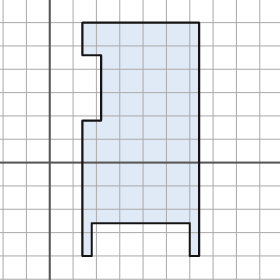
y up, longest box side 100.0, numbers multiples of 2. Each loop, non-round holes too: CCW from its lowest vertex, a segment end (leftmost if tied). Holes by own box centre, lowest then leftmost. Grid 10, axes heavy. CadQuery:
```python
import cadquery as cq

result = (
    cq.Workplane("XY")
    .moveTo(14.0, -40.0)
    .lineTo(18.0, -40.0)
    .lineTo(18.0, -26.0)
    .lineTo(60.0, -26.0)
    .lineTo(60.0, -40.0)
    .lineTo(64.0, -40.0)
    .lineTo(64.0, 60.0)
    .lineTo(14.0, 60.0)
    .lineTo(14.0, 46.0)
    .lineTo(22.0, 46.0)
    .lineTo(22.0, 18.0)
    .lineTo(14.0, 18.0)
    .close()
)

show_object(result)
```